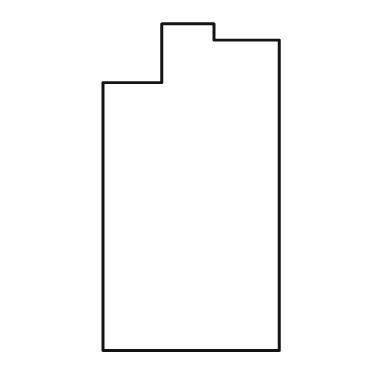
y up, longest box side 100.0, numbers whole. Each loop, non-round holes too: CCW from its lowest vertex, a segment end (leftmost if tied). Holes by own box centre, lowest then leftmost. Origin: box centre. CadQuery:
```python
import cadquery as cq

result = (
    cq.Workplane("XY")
    .moveTo(-27.0, -50.0)
    .lineTo(27.0, -50.0)
    .lineTo(27.0, 45.0)
    .lineTo(7.0, 45.0)
    .lineTo(7.0, 50.0)
    .lineTo(-9.0, 50.0)
    .lineTo(-9.0, 32.0)
    .lineTo(-27.0, 32.0)
    .close()
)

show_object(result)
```